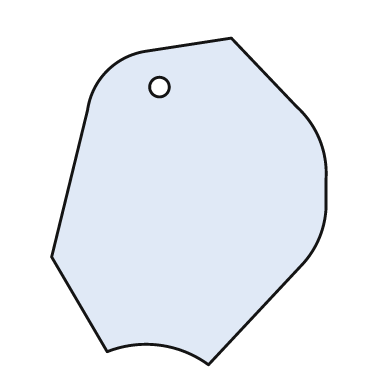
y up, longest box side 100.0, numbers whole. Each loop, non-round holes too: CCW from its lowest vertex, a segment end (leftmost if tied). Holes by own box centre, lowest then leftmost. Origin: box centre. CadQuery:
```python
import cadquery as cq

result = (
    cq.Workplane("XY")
    .moveTo(6.0, -50.0)
    .lineTo(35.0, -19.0)
    .threePointArc((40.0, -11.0), (42.0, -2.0))
    .lineTo(42.0, 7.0)
    .threePointArc((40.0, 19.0), (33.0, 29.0))
    .lineTo(13.0, 50.0)
    .lineTo(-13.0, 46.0)
    .threePointArc((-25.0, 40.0), (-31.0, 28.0))
    .lineTo(-42.0, -17.0)
    .lineTo(-25.0, -46.0)
    .threePointArc((-9.0, -44.0), (6.0, -50.0))
    .close()
    .moveTo(-9.0, 35.0)
    .circle(3.0)
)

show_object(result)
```